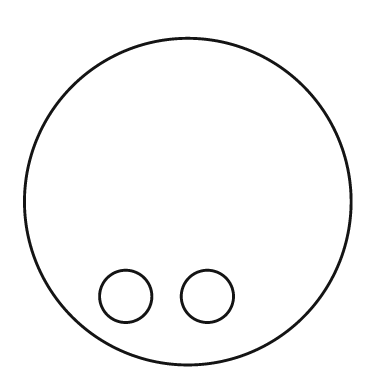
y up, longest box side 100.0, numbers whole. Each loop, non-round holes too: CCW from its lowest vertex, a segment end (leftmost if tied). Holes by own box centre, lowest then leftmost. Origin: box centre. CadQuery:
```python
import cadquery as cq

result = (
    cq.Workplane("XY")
    .moveTo(0.0, 0.0)
    .circle(50.0)
    .moveTo(-19.0, -29.0)
    .circle(8.0)
    .moveTo(6.0, -29.0)
    .circle(8.0)
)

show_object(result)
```